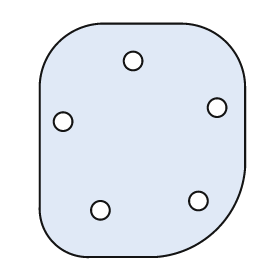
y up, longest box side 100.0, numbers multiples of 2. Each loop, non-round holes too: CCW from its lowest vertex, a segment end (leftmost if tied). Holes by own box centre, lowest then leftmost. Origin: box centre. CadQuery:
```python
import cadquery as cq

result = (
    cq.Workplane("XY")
    .moveTo(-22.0, -50.0)
    .lineTo(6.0, -50.0)
    .threePointArc((32.0, -38.0), (44.0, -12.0))
    .lineTo(44.0, 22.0)
    .threePointArc((36.0, 42.0), (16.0, 50.0))
    .lineTo(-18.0, 50.0)
    .threePointArc((-36.0, 42.0), (-44.0, 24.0))
    .lineTo(-44.0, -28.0)
    .threePointArc((-38.0, -44.0), (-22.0, -50.0))
    .close()
    .moveTo(-18.0, -30.0)
    .circle(4.0)
    .moveTo(24.0, -26.0)
    .circle(4.0)
    .moveTo(-34.0, 8.0)
    .circle(4.0)
    .moveTo(32.0, 14.0)
    .circle(4.0)
    .moveTo(-4.0, 34.0)
    .circle(4.0)
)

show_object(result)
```